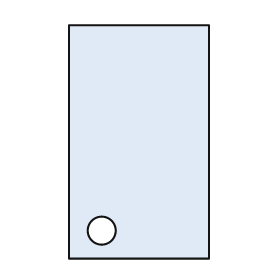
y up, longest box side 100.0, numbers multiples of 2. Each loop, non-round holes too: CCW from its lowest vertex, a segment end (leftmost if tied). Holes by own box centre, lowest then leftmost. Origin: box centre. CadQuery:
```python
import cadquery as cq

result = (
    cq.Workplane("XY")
    .moveTo(-30.0, -50.0)
    .lineTo(30.0, -50.0)
    .lineTo(30.0, 50.0)
    .lineTo(-30.0, 50.0)
    .close()
    .moveTo(-16.0, -38.0)
    .circle(6.0)
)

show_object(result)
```